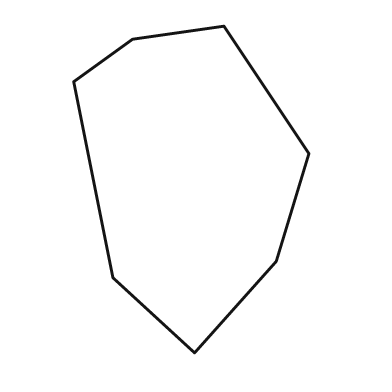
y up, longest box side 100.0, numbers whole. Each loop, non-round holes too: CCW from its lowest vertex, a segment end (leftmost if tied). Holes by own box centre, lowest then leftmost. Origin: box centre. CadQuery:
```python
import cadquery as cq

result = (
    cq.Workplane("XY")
    .moveTo(1.0, -50.0)
    .lineTo(26.0, -22.0)
    .lineTo(36.0, 11.0)
    .lineTo(10.0, 50.0)
    .lineTo(-18.0, 46.0)
    .lineTo(-36.0, 33.0)
    .lineTo(-24.0, -27.0)
    .close()
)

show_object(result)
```